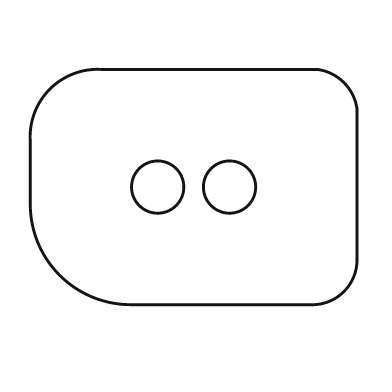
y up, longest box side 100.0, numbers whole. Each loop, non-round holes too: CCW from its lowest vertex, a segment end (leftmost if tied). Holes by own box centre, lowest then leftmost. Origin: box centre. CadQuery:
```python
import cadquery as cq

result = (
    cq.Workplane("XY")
    .moveTo(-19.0, -36.0)
    .lineTo(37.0, -36.0)
    .threePointArc((46.0, -32.0), (50.0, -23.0))
    .lineTo(50.0, 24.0)
    .threePointArc((46.0, 32.0), (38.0, 36.0))
    .lineTo(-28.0, 36.0)
    .threePointArc((-44.0, 30.0), (-50.0, 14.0))
    .lineTo(-50.0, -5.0)
    .threePointArc((-41.0, -27.0), (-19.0, -36.0))
    .close()
    .moveTo(-11.0, 0.0)
    .circle(8.0)
    .moveTo(11.0, 0.0)
    .circle(8.0)
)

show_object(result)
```